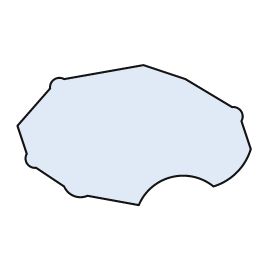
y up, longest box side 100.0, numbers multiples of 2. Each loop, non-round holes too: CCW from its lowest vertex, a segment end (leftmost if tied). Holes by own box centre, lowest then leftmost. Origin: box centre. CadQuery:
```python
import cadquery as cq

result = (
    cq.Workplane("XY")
    .moveTo(2.0, -30.0)
    .threePointArc((16.0, -18.0), (34.0, -22.0))
    .threePointArc((44.0, -16.0), (50.0, -6.0))
    .lineTo(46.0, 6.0)
    .threePointArc((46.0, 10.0), (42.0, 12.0))
    .lineTo(22.0, 24.0)
    .lineTo(4.0, 30.0)
    .lineTo(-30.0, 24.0)
    .threePointArc((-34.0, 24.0), (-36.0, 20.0))
    .lineTo(-50.0, 4.0)
    .lineTo(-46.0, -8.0)
    .threePointArc((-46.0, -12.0), (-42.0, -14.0))
    .lineTo(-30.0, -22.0)
    .threePointArc((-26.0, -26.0), (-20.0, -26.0))
    .close()
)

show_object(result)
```